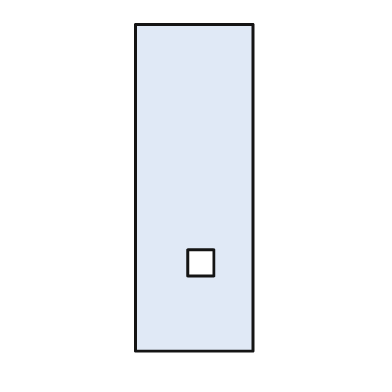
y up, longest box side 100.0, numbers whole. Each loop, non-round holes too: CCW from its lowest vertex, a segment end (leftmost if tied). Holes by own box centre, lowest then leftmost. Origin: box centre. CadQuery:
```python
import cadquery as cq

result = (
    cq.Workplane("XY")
    .moveTo(-18.0, -50.0)
    .lineTo(18.0, -50.0)
    .lineTo(18.0, 50.0)
    .lineTo(-18.0, 50.0)
    .close()
    .moveTo(-2.0, -27.0)
    .lineTo(6.0, -27.0)
    .lineTo(6.0, -19.0)
    .lineTo(-2.0, -19.0)
    .close()
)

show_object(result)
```